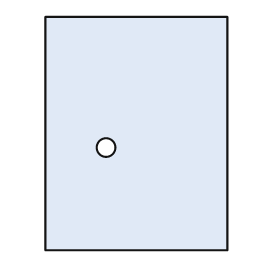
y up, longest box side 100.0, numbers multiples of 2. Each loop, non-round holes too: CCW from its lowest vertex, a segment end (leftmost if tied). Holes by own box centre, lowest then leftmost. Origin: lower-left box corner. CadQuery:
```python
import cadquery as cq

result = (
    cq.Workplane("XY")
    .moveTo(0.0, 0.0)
    .lineTo(78.0, 0.0)
    .lineTo(78.0, 100.0)
    .lineTo(0.0, 100.0)
    .close()
    .moveTo(26.0, 44.0)
    .circle(4.0)
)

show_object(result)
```